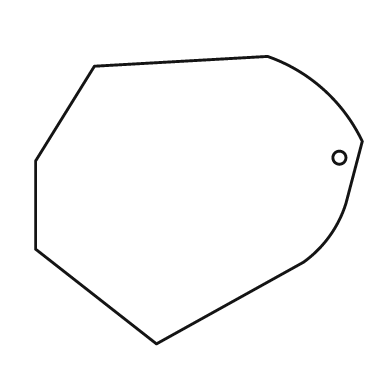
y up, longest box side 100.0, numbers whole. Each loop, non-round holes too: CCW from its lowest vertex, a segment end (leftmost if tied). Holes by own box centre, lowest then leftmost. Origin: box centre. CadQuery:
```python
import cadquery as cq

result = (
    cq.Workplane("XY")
    .moveTo(-13.0, -44.0)
    .lineTo(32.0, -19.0)
    .threePointArc((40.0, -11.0), (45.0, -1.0))
    .lineTo(50.0, 18.0)
    .threePointArc((38.0, 34.0), (21.0, 44.0))
    .lineTo(-32.0, 41.0)
    .lineTo(-50.0, 12.0)
    .lineTo(-50.0, -15.0)
    .close()
    .moveTo(43.0, 13.0)
    .circle(2.0)
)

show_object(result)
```